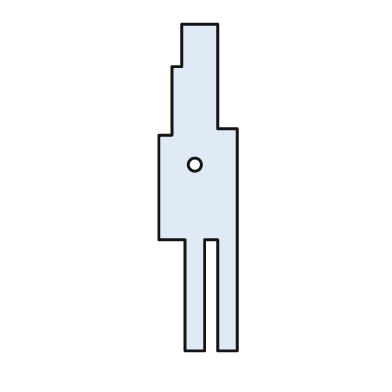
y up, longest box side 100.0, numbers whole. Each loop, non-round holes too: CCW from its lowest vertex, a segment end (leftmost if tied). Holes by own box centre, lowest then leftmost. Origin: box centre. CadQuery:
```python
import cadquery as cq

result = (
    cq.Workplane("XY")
    .moveTo(-4.0, -50.0)
    .lineTo(2.0, -50.0)
    .lineTo(2.0, -16.0)
    .lineTo(6.0, -16.0)
    .lineTo(6.0, -50.0)
    .lineTo(12.0, -50.0)
    .lineTo(12.0, 18.0)
    .lineTo(6.0, 18.0)
    .lineTo(6.0, 50.0)
    .lineTo(-5.0, 50.0)
    .lineTo(-5.0, 37.0)
    .lineTo(-8.0, 37.0)
    .lineTo(-8.0, 16.0)
    .lineTo(-12.0, 16.0)
    .lineTo(-12.0, -16.0)
    .lineTo(-4.0, -16.0)
    .close()
    .moveTo(-1.0, 7.0)
    .circle(2.0)
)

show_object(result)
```